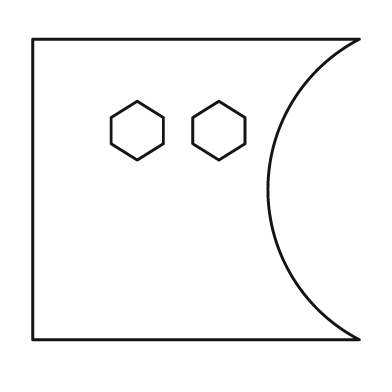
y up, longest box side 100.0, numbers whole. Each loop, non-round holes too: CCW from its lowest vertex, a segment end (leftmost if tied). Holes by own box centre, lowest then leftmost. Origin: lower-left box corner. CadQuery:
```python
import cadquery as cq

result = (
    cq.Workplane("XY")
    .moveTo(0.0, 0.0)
    .lineTo(100.0, 0.0)
    .threePointArc((72.0, 46.0), (100.0, 92.0))
    .lineTo(0.0, 92.0)
    .close()
    .moveTo(32.0, 55.0)
    .lineTo(40.0, 60.0)
    .lineTo(40.0, 68.0)
    .lineTo(32.0, 73.0)
    .lineTo(24.0, 68.0)
    .lineTo(24.0, 60.0)
    .close()
    .moveTo(57.0, 55.0)
    .lineTo(65.0, 60.0)
    .lineTo(65.0, 68.0)
    .lineTo(57.0, 73.0)
    .lineTo(49.0, 68.0)
    .lineTo(49.0, 60.0)
    .close()
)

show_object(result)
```